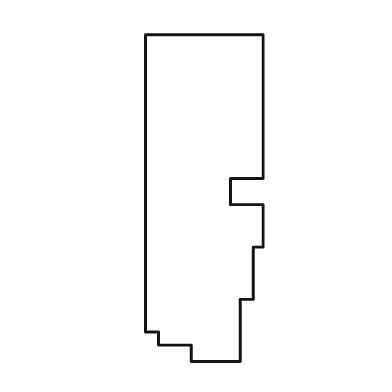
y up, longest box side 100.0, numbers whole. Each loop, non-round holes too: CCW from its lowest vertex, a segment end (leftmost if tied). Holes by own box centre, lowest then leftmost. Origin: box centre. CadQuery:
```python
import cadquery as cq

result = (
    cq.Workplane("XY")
    .moveTo(-4.0, -50.0)
    .lineTo(11.0, -50.0)
    .lineTo(11.0, -31.0)
    .lineTo(15.0, -31.0)
    .lineTo(15.0, -15.0)
    .lineTo(18.0, -15.0)
    .lineTo(18.0, -2.0)
    .lineTo(8.0, -2.0)
    .lineTo(8.0, 6.0)
    .lineTo(18.0, 6.0)
    .lineTo(18.0, 50.0)
    .lineTo(-18.0, 50.0)
    .lineTo(-18.0, -41.0)
    .lineTo(-14.0, -41.0)
    .lineTo(-14.0, -45.0)
    .lineTo(-4.0, -45.0)
    .close()
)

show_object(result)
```